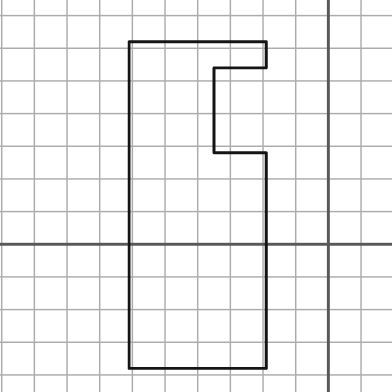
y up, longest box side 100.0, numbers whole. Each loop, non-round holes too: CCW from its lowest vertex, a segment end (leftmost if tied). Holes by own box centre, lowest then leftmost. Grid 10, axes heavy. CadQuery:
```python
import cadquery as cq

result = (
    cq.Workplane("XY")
    .moveTo(-61.0, -38.0)
    .lineTo(-19.0, -38.0)
    .lineTo(-19.0, 28.0)
    .lineTo(-35.0, 28.0)
    .lineTo(-35.0, 54.0)
    .lineTo(-19.0, 54.0)
    .lineTo(-19.0, 62.0)
    .lineTo(-61.0, 62.0)
    .close()
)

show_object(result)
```